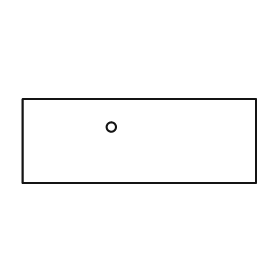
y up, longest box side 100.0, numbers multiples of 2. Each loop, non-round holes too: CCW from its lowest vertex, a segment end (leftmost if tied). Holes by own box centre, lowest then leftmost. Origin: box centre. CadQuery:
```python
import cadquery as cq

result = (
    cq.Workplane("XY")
    .moveTo(-50.0, -18.0)
    .lineTo(50.0, -18.0)
    .lineTo(50.0, 18.0)
    .lineTo(-50.0, 18.0)
    .close()
    .moveTo(-12.0, 6.0)
    .circle(2.0)
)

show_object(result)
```